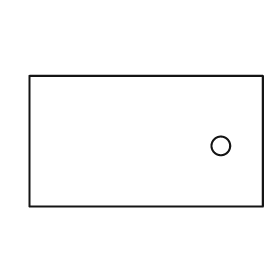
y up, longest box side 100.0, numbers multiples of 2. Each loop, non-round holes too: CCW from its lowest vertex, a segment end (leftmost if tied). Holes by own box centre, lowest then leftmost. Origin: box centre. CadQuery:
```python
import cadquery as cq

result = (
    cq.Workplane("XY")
    .moveTo(-50.0, -28.0)
    .lineTo(50.0, -28.0)
    .lineTo(50.0, 28.0)
    .lineTo(-50.0, 28.0)
    .close()
    .moveTo(32.0, -2.0)
    .circle(4.0)
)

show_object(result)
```